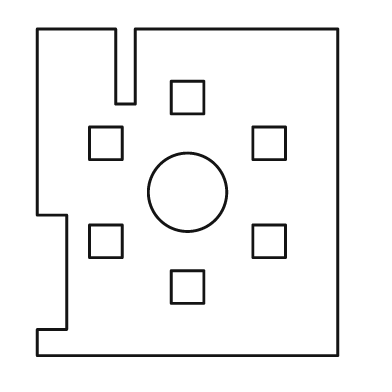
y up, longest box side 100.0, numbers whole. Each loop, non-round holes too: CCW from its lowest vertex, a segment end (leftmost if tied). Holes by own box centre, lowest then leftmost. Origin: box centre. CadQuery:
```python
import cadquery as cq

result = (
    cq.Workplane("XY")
    .moveTo(-46.0, -50.0)
    .lineTo(46.0, -50.0)
    .lineTo(46.0, 50.0)
    .lineTo(-16.0, 50.0)
    .lineTo(-16.0, 27.0)
    .lineTo(-22.0, 27.0)
    .lineTo(-22.0, 50.0)
    .lineTo(-46.0, 50.0)
    .lineTo(-46.0, -7.0)
    .lineTo(-37.0, -7.0)
    .lineTo(-37.0, -42.0)
    .lineTo(-46.0, -42.0)
    .close()
    .moveTo(-5.0, -34.0)
    .lineTo(5.0, -34.0)
    .lineTo(5.0, -24.0)
    .lineTo(-5.0, -24.0)
    .close()
    .moveTo(-30.0, -20.0)
    .lineTo(-20.0, -20.0)
    .lineTo(-20.0, -10.0)
    .lineTo(-30.0, -10.0)
    .close()
    .moveTo(20.0, -20.0)
    .lineTo(30.0, -20.0)
    .lineTo(30.0, -10.0)
    .lineTo(20.0, -10.0)
    .close()
    .moveTo(0.0, 0.0)
    .circle(12.0)
    .moveTo(-30.0, 10.0)
    .lineTo(-20.0, 10.0)
    .lineTo(-20.0, 20.0)
    .lineTo(-30.0, 20.0)
    .close()
    .moveTo(20.0, 10.0)
    .lineTo(30.0, 10.0)
    .lineTo(30.0, 20.0)
    .lineTo(20.0, 20.0)
    .close()
    .moveTo(-5.0, 24.0)
    .lineTo(5.0, 24.0)
    .lineTo(5.0, 34.0)
    .lineTo(-5.0, 34.0)
    .close()
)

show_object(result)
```